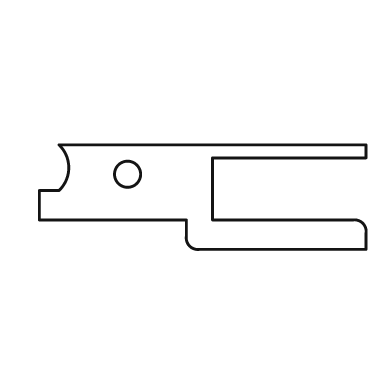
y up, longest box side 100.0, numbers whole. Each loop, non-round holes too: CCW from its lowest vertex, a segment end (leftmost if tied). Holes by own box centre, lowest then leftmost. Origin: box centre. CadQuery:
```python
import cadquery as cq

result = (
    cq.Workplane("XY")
    .moveTo(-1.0, -16.0)
    .lineTo(50.0, -16.0)
    .lineTo(50.0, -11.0)
    .threePointArc((49.0, -8.0), (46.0, -7.0))
    .lineTo(3.0, -7.0)
    .lineTo(3.0, 12.0)
    .lineTo(50.0, 12.0)
    .lineTo(50.0, 16.0)
    .lineTo(-44.0, 16.0)
    .threePointArc((-41.0, 9.0), (-44.0, 2.0))
    .lineTo(-50.0, 2.0)
    .lineTo(-50.0, -7.0)
    .lineTo(-5.0, -7.0)
    .lineTo(-5.0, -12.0)
    .threePointArc((-4.0, -15.0), (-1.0, -16.0))
    .close()
    .moveTo(-23.0, 7.0)
    .circle(4.0)
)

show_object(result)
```